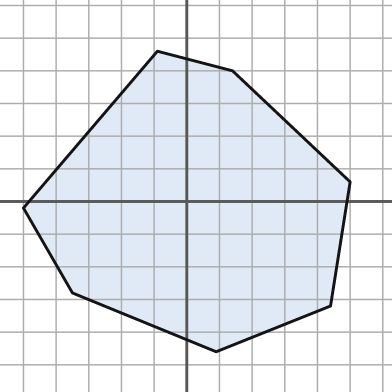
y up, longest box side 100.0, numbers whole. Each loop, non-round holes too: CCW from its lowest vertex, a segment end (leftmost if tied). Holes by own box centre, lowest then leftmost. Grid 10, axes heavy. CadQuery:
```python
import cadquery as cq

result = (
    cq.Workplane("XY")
    .moveTo(9.0, -46.0)
    .lineTo(44.0, -32.0)
    .lineTo(50.0, 6.0)
    .lineTo(14.0, 40.0)
    .lineTo(-9.0, 46.0)
    .lineTo(-50.0, -2.0)
    .lineTo(-35.0, -28.0)
    .close()
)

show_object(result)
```